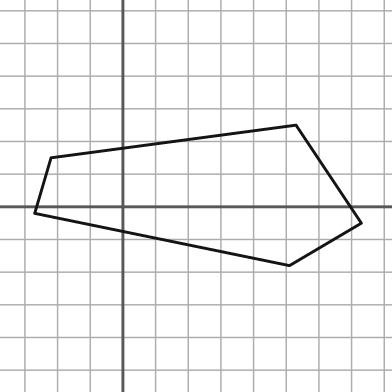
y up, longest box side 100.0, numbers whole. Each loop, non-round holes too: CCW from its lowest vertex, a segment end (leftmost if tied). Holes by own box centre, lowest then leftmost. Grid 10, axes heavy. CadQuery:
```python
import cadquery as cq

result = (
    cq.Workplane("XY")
    .moveTo(51.0, -18.0)
    .lineTo(73.0, -5.0)
    .lineTo(53.0, 25.0)
    .lineTo(-22.0, 15.0)
    .lineTo(-27.0, -2.0)
    .close()
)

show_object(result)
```